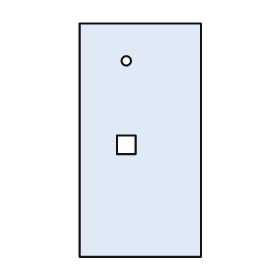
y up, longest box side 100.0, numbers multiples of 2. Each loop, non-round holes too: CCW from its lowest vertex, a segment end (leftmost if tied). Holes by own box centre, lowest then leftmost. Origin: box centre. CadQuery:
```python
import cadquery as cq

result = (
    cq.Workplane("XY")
    .moveTo(-26.0, -50.0)
    .lineTo(26.0, -50.0)
    .lineTo(26.0, 50.0)
    .lineTo(-26.0, 50.0)
    .close()
    .moveTo(-10.0, -6.0)
    .lineTo(-2.0, -6.0)
    .lineTo(-2.0, 2.0)
    .lineTo(-10.0, 2.0)
    .close()
    .moveTo(-6.0, 34.0)
    .circle(2.0)
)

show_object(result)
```